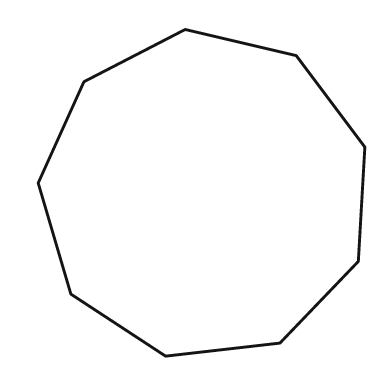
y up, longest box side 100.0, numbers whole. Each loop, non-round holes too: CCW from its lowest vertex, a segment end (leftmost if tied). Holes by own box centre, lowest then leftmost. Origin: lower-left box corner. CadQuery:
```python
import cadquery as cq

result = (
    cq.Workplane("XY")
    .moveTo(39.0, 0.0)
    .lineTo(74.0, 4.0)
    .lineTo(98.0, 29.0)
    .lineTo(100.0, 64.0)
    .lineTo(79.0, 92.0)
    .lineTo(45.0, 100.0)
    .lineTo(14.0, 84.0)
    .lineTo(0.0, 53.0)
    .lineTo(10.0, 19.0)
    .close()
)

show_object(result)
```